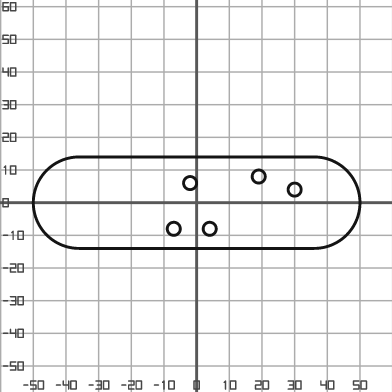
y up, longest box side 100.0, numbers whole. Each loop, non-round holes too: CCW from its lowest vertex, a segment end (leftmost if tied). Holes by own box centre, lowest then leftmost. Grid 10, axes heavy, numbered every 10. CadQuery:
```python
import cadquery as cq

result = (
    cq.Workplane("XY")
    .moveTo(-36.0, -14.0)
    .lineTo(36.0, -14.0)
    .threePointArc((50.0, 0.0), (36.0, 14.0))
    .lineTo(-36.0, 14.0)
    .threePointArc((-50.0, 0.0), (-36.0, -14.0))
    .close()
    .moveTo(-7.0, -8.0)
    .circle(2.0)
    .moveTo(4.0, -8.0)
    .circle(2.0)
    .moveTo(30.0, 4.0)
    .circle(2.0)
    .moveTo(-2.0, 6.0)
    .circle(2.0)
    .moveTo(19.0, 8.0)
    .circle(2.0)
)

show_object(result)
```